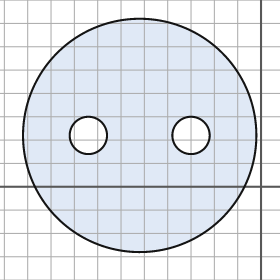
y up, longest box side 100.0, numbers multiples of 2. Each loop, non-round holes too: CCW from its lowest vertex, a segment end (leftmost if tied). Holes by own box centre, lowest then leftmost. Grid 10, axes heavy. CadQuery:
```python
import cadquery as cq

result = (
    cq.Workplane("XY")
    .moveTo(-52.0, 22.0)
    .circle(50.0)
    .moveTo(-74.0, 22.0)
    .circle(8.0)
    .moveTo(-30.0, 22.0)
    .circle(8.0)
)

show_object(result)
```